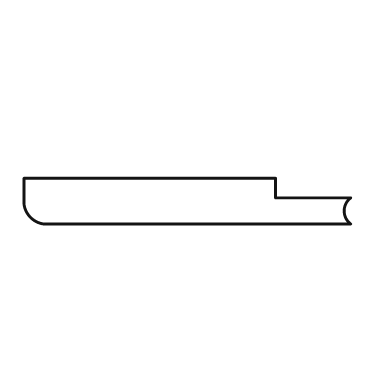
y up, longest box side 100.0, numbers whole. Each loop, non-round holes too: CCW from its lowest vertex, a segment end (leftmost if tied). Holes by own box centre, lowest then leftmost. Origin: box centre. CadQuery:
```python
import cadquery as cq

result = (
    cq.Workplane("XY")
    .moveTo(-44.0, -7.0)
    .lineTo(50.0, -7.0)
    .threePointArc((48.0, -3.0), (50.0, 1.0))
    .lineTo(27.0, 1.0)
    .lineTo(27.0, 7.0)
    .lineTo(-50.0, 7.0)
    .lineTo(-50.0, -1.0)
    .threePointArc((-48.0, -5.0), (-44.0, -7.0))
    .close()
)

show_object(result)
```